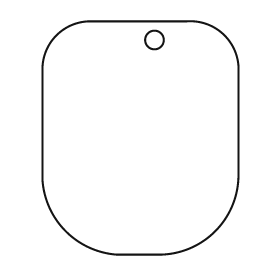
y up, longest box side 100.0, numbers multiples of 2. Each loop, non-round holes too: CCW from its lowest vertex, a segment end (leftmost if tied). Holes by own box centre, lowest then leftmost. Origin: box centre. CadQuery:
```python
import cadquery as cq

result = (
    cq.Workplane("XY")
    .moveTo(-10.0, -50.0)
    .lineTo(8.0, -50.0)
    .threePointArc((32.0, -40.0), (42.0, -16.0))
    .lineTo(42.0, 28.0)
    .threePointArc((36.0, 44.0), (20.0, 50.0))
    .lineTo(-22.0, 50.0)
    .threePointArc((-36.0, 44.0), (-42.0, 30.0))
    .lineTo(-42.0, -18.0)
    .threePointArc((-32.0, -40.0), (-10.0, -50.0))
    .close()
    .moveTo(6.0, 42.0)
    .circle(4.0)
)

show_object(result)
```